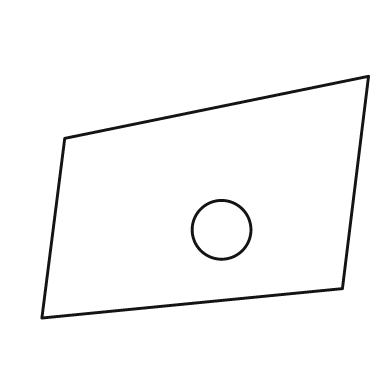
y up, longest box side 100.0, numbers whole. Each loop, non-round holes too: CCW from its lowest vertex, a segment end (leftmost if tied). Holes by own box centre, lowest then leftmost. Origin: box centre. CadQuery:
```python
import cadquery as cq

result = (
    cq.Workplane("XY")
    .moveTo(-50.0, -37.0)
    .lineTo(42.0, -28.0)
    .lineTo(50.0, 37.0)
    .lineTo(-43.0, 18.0)
    .close()
    .moveTo(5.0, -10.0)
    .circle(9.0)
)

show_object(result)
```